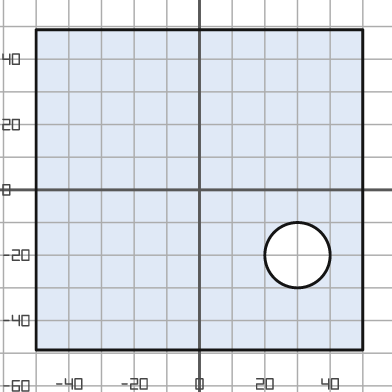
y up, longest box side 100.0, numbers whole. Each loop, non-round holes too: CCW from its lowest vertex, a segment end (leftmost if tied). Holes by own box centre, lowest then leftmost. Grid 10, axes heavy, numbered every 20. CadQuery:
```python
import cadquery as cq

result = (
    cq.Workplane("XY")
    .moveTo(-50.0, -49.0)
    .lineTo(50.0, -49.0)
    .lineTo(50.0, 49.0)
    .lineTo(-50.0, 49.0)
    .close()
    .moveTo(30.0, -20.0)
    .circle(10.0)
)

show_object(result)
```